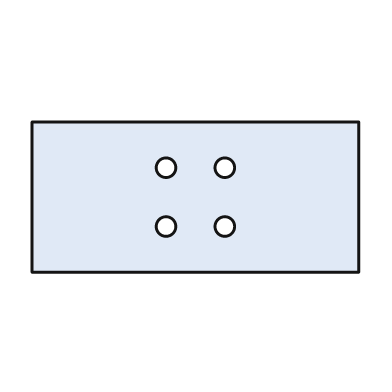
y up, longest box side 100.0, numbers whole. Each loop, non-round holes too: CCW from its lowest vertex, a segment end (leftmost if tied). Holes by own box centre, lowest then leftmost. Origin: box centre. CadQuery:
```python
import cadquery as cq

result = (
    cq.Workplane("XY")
    .moveTo(-50.0, -23.0)
    .lineTo(50.0, -23.0)
    .lineTo(50.0, 23.0)
    .lineTo(-50.0, 23.0)
    .close()
    .moveTo(-9.0, -9.0)
    .circle(3.0)
    .moveTo(9.0, -9.0)
    .circle(3.0)
    .moveTo(-9.0, 9.0)
    .circle(3.0)
    .moveTo(9.0, 9.0)
    .circle(3.0)
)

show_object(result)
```